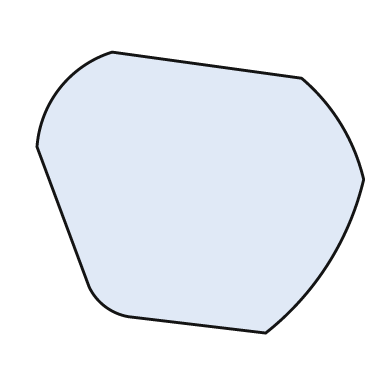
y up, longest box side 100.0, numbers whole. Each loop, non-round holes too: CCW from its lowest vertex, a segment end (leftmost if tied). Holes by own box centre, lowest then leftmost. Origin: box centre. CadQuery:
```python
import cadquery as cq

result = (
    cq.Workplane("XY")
    .moveTo(20.0, -43.0)
    .threePointArc((39.0, -22.0), (50.0, 4.0))
    .threePointArc((43.0, 21.0), (31.0, 35.0))
    .lineTo(-27.0, 43.0)
    .threePointArc((-43.0, 32.0), (-50.0, 14.0))
    .lineTo(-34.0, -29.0)
    .threePointArc((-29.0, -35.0), (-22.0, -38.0))
    .close()
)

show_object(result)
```